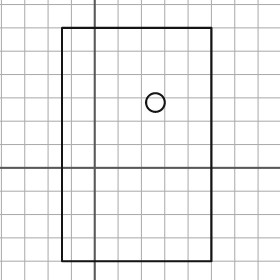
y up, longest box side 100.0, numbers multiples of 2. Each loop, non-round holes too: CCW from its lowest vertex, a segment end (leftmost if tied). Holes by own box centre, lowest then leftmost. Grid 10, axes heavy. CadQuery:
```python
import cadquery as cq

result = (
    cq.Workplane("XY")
    .moveTo(-14.0, -40.0)
    .lineTo(50.0, -40.0)
    .lineTo(50.0, 60.0)
    .lineTo(-14.0, 60.0)
    .close()
    .moveTo(26.0, 28.0)
    .circle(4.0)
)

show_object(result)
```